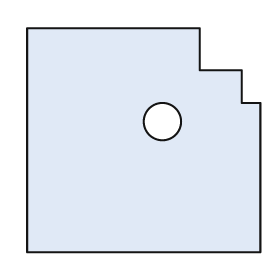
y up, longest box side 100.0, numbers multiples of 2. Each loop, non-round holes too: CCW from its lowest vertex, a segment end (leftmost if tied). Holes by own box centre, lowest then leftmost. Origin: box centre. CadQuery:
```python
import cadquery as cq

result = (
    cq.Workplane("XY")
    .moveTo(-50.0, -48.0)
    .lineTo(50.0, -48.0)
    .lineTo(50.0, 16.0)
    .lineTo(42.0, 16.0)
    .lineTo(42.0, 30.0)
    .lineTo(24.0, 30.0)
    .lineTo(24.0, 48.0)
    .lineTo(-50.0, 48.0)
    .close()
    .moveTo(8.0, 8.0)
    .circle(8.0)
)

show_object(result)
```